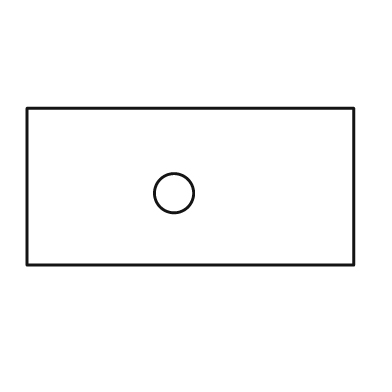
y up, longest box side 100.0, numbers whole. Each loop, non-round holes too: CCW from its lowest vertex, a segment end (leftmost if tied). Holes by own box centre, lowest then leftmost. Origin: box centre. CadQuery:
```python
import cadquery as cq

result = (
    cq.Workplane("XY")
    .moveTo(-50.0, -24.0)
    .lineTo(50.0, -24.0)
    .lineTo(50.0, 24.0)
    .lineTo(-50.0, 24.0)
    .close()
    .moveTo(-5.0, -2.0)
    .circle(6.0)
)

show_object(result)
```